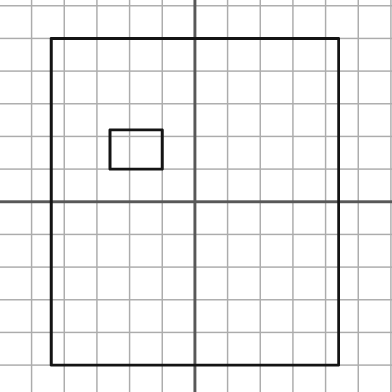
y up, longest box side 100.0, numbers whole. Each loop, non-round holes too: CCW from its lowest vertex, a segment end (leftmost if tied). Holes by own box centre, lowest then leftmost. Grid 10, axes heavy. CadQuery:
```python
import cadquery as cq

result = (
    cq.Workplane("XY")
    .moveTo(-44.0, -50.0)
    .lineTo(44.0, -50.0)
    .lineTo(44.0, 50.0)
    .lineTo(-44.0, 50.0)
    .close()
    .moveTo(-26.0, 10.0)
    .lineTo(-10.0, 10.0)
    .lineTo(-10.0, 22.0)
    .lineTo(-26.0, 22.0)
    .close()
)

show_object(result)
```